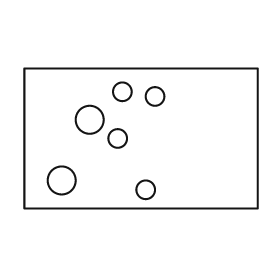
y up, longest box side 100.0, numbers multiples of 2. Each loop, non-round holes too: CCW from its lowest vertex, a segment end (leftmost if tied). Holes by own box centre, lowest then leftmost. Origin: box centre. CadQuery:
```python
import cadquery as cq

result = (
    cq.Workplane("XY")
    .moveTo(-50.0, -30.0)
    .lineTo(50.0, -30.0)
    .lineTo(50.0, 30.0)
    .lineTo(-50.0, 30.0)
    .close()
    .moveTo(2.0, -22.0)
    .circle(4.0)
    .moveTo(-34.0, -18.0)
    .circle(6.0)
    .moveTo(-10.0, 0.0)
    .circle(4.0)
    .moveTo(-22.0, 8.0)
    .circle(6.0)
    .moveTo(6.0, 18.0)
    .circle(4.0)
    .moveTo(-8.0, 20.0)
    .circle(4.0)
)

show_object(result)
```